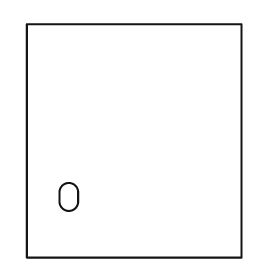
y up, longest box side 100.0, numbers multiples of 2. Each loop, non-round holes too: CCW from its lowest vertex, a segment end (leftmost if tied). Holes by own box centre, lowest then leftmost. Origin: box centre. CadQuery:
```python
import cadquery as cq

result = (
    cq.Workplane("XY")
    .moveTo(-46.0, -50.0)
    .lineTo(46.0, -50.0)
    .lineTo(46.0, 50.0)
    .lineTo(-46.0, 50.0)
    .close()
    .moveTo(-32.0, -26.0)
    .threePointArc((-28.0, -30.0), (-24.0, -26.0))
    .lineTo(-24.0, -22.0)
    .threePointArc((-28.0, -18.0), (-32.0, -22.0))
    .close()
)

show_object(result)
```